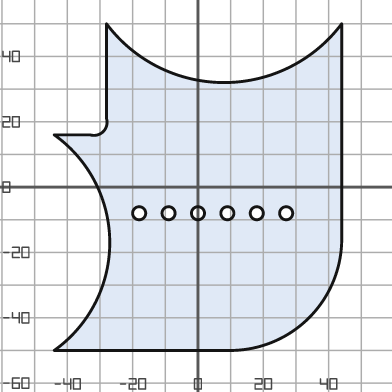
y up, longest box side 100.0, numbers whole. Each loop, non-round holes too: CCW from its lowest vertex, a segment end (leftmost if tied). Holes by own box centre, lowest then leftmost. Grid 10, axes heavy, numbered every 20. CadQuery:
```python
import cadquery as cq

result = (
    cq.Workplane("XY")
    .moveTo(-44.0, -50.0)
    .lineTo(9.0, -50.0)
    .threePointArc((34.0, -40.0), (44.0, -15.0))
    .lineTo(44.0, 50.0)
    .threePointArc((8.0, 32.0), (-28.0, 50.0))
    .lineTo(-28.0, 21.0)
    .threePointArc((-29.0, 17.0), (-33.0, 16.0))
    .lineTo(-44.0, 16.0)
    .threePointArc((-27.0, -17.0), (-44.0, -50.0))
    .close()
    .moveTo(-18.0, -8.0)
    .circle(2.0)
    .moveTo(-9.0, -8.0)
    .circle(2.0)
    .moveTo(0.0, -8.0)
    .circle(2.0)
    .moveTo(9.0, -8.0)
    .circle(2.0)
    .moveTo(18.0, -8.0)
    .circle(2.0)
    .moveTo(27.0, -8.0)
    .circle(2.0)
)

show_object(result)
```